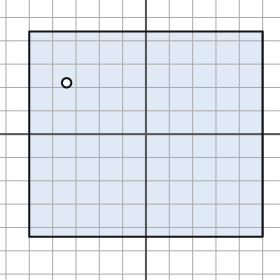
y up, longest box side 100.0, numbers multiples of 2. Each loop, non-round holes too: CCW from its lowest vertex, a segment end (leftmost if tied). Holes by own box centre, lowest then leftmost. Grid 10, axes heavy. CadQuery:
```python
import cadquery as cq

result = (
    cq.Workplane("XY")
    .moveTo(-50.0, -44.0)
    .lineTo(50.0, -44.0)
    .lineTo(50.0, 44.0)
    .lineTo(-50.0, 44.0)
    .close()
    .moveTo(-34.0, 22.0)
    .circle(2.0)
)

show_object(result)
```